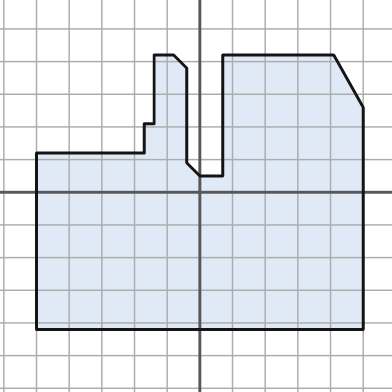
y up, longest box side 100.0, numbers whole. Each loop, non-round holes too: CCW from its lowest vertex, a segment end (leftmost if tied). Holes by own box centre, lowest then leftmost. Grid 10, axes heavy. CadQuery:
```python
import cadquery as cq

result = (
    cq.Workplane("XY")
    .moveTo(-50.0, -42.0)
    .lineTo(50.0, -42.0)
    .lineTo(50.0, 26.0)
    .lineTo(41.0, 42.0)
    .lineTo(7.0, 42.0)
    .lineTo(7.0, 5.0)
    .lineTo(0.0, 5.0)
    .lineTo(-4.0, 9.0)
    .lineTo(-4.0, 38.0)
    .lineTo(-8.0, 42.0)
    .lineTo(-14.0, 42.0)
    .lineTo(-14.0, 21.0)
    .lineTo(-17.0, 21.0)
    .lineTo(-17.0, 12.0)
    .lineTo(-50.0, 12.0)
    .close()
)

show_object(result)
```